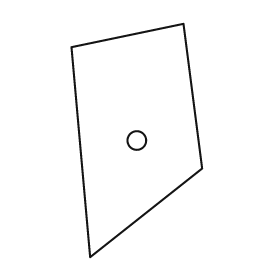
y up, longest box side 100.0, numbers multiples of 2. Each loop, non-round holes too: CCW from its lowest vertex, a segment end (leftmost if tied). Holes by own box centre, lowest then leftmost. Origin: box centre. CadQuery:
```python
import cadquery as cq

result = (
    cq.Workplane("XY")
    .moveTo(-20.0, -50.0)
    .lineTo(28.0, -12.0)
    .lineTo(20.0, 50.0)
    .lineTo(-28.0, 40.0)
    .close()
    .moveTo(0.0, 0.0)
    .circle(4.0)
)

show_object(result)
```